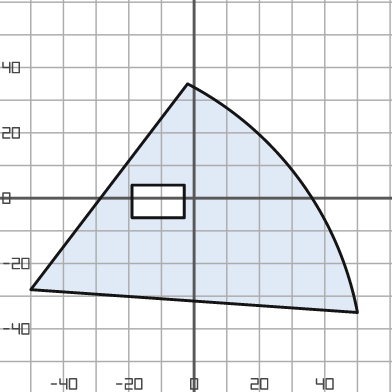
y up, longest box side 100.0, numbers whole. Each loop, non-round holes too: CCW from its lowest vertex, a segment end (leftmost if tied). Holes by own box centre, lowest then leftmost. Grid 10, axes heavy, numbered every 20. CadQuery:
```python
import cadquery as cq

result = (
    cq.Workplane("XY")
    .moveTo(50.0, -35.0)
    .threePointArc((32.0, 6.0), (-2.0, 35.0))
    .lineTo(-50.0, -28.0)
    .close()
    .moveTo(-19.0, -6.0)
    .lineTo(-3.0, -6.0)
    .lineTo(-3.0, 4.0)
    .lineTo(-19.0, 4.0)
    .close()
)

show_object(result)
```